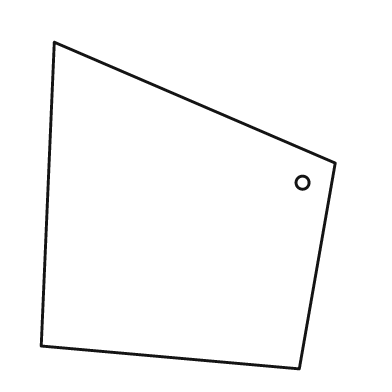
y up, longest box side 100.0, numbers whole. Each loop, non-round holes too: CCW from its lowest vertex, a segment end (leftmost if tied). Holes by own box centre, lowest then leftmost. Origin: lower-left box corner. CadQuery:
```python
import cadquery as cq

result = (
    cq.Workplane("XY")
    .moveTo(79.0, 0.0)
    .lineTo(90.0, 63.0)
    .lineTo(4.0, 100.0)
    .lineTo(0.0, 7.0)
    .close()
    .moveTo(80.0, 57.0)
    .circle(2.0)
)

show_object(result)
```